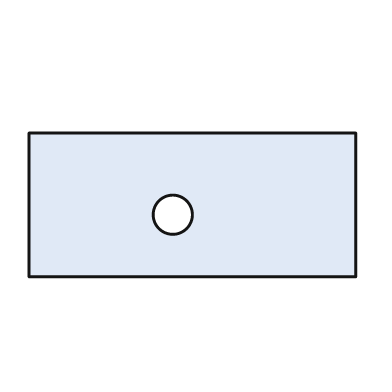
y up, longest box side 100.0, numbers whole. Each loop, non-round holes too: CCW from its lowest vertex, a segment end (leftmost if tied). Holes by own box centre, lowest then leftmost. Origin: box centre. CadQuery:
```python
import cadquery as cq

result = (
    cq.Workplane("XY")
    .moveTo(-50.0, -22.0)
    .lineTo(50.0, -22.0)
    .lineTo(50.0, 22.0)
    .lineTo(-50.0, 22.0)
    .close()
    .moveTo(-6.0, -3.0)
    .circle(6.0)
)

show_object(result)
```